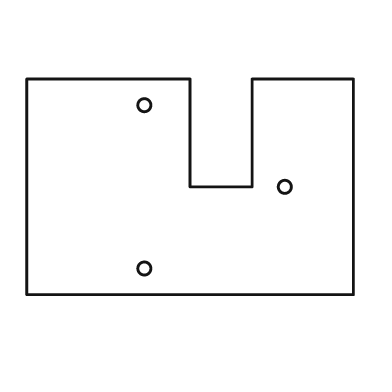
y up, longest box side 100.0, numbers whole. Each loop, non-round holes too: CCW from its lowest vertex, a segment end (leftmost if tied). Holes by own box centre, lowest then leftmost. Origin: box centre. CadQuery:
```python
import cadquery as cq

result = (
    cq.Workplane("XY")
    .moveTo(-50.0, -33.0)
    .lineTo(50.0, -33.0)
    .lineTo(50.0, 33.0)
    .lineTo(19.0, 33.0)
    .lineTo(19.0, 0.0)
    .lineTo(0.0, 0.0)
    .lineTo(0.0, 33.0)
    .lineTo(-50.0, 33.0)
    .close()
    .moveTo(-14.0, -25.0)
    .circle(2.0)
    .moveTo(29.0, 0.0)
    .circle(2.0)
    .moveTo(-14.0, 25.0)
    .circle(2.0)
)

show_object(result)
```